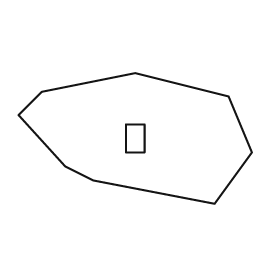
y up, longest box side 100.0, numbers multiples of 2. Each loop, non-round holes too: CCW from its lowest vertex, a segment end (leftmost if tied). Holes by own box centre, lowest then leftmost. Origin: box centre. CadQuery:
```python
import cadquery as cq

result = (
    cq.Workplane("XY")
    .moveTo(34.0, -28.0)
    .lineTo(50.0, -6.0)
    .lineTo(40.0, 18.0)
    .lineTo(0.0, 28.0)
    .lineTo(-40.0, 20.0)
    .lineTo(-50.0, 10.0)
    .lineTo(-30.0, -12.0)
    .lineTo(-18.0, -18.0)
    .close()
    .moveTo(-4.0, -6.0)
    .lineTo(4.0, -6.0)
    .lineTo(4.0, 6.0)
    .lineTo(-4.0, 6.0)
    .close()
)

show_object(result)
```